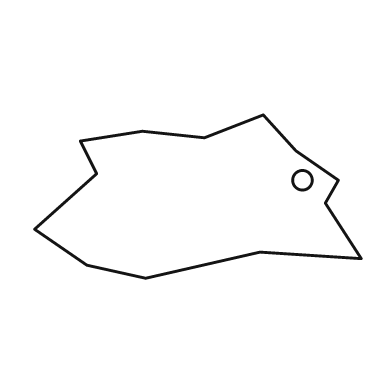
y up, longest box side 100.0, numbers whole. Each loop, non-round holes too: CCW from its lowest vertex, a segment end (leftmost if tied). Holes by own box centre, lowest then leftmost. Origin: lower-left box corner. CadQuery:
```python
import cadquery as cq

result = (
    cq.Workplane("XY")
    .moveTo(34.0, 0.0)
    .lineTo(69.0, 8.0)
    .lineTo(100.0, 6.0)
    .lineTo(89.0, 23.0)
    .lineTo(93.0, 30.0)
    .lineTo(80.0, 39.0)
    .lineTo(70.0, 50.0)
    .lineTo(52.0, 43.0)
    .lineTo(33.0, 45.0)
    .lineTo(14.0, 42.0)
    .lineTo(19.0, 32.0)
    .lineTo(0.0, 15.0)
    .lineTo(16.0, 4.0)
    .close()
    .moveTo(82.0, 30.0)
    .circle(3.0)
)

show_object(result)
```